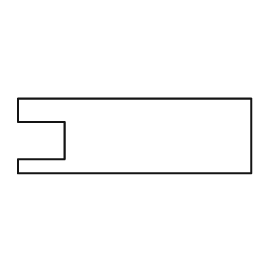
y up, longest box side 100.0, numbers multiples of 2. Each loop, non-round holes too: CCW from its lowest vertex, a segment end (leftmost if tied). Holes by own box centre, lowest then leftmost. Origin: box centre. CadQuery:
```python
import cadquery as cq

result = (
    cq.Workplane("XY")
    .moveTo(-50.0, -16.0)
    .lineTo(50.0, -16.0)
    .lineTo(50.0, 16.0)
    .lineTo(-50.0, 16.0)
    .lineTo(-50.0, 6.0)
    .lineTo(-30.0, 6.0)
    .lineTo(-30.0, -10.0)
    .lineTo(-50.0, -10.0)
    .close()
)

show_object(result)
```